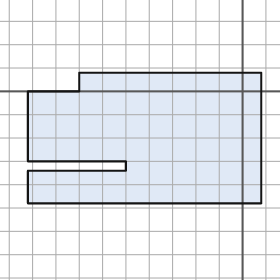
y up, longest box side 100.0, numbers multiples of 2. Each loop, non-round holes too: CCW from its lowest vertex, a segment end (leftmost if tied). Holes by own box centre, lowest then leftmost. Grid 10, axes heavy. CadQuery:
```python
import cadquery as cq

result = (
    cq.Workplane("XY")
    .moveTo(-92.0, -48.0)
    .lineTo(8.0, -48.0)
    .lineTo(8.0, 8.0)
    .lineTo(-70.0, 8.0)
    .lineTo(-70.0, 0.0)
    .lineTo(-92.0, 0.0)
    .lineTo(-92.0, -30.0)
    .lineTo(-50.0, -30.0)
    .lineTo(-50.0, -34.0)
    .lineTo(-92.0, -34.0)
    .close()
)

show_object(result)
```